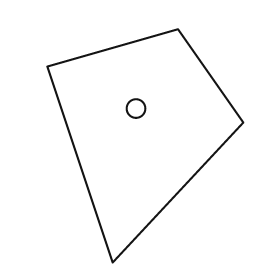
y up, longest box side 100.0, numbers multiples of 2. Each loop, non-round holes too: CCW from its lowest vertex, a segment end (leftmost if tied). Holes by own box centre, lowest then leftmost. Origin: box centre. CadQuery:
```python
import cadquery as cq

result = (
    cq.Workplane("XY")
    .moveTo(-14.0, -50.0)
    .lineTo(42.0, 10.0)
    .lineTo(14.0, 50.0)
    .lineTo(-42.0, 34.0)
    .close()
    .moveTo(-4.0, 16.0)
    .circle(4.0)
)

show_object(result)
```